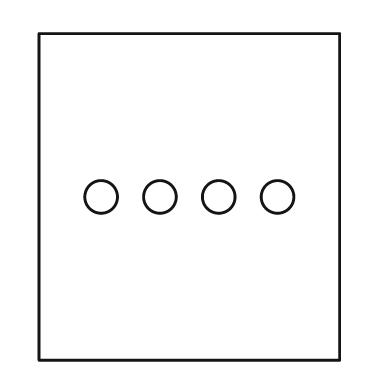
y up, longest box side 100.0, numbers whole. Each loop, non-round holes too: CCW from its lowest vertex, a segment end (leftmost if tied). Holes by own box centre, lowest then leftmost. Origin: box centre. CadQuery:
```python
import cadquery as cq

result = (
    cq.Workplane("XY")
    .moveTo(-46.0, -50.0)
    .lineTo(46.0, -50.0)
    .lineTo(46.0, 50.0)
    .lineTo(-46.0, 50.0)
    .close()
    .moveTo(-27.0, 0.0)
    .circle(5.0)
    .moveTo(-9.0, 0.0)
    .circle(5.0)
    .moveTo(9.0, 0.0)
    .circle(5.0)
    .moveTo(27.0, 0.0)
    .circle(5.0)
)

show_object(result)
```